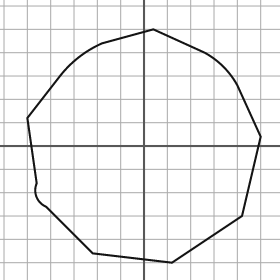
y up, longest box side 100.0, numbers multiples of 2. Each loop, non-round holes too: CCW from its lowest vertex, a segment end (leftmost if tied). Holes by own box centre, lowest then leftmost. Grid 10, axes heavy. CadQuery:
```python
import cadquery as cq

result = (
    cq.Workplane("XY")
    .moveTo(12.0, -50.0)
    .lineTo(42.0, -30.0)
    .lineTo(50.0, 4.0)
    .lineTo(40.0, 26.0)
    .threePointArc((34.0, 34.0), (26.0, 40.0))
    .lineTo(4.0, 50.0)
    .lineTo(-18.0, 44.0)
    .threePointArc((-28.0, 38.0), (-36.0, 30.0))
    .lineTo(-50.0, 12.0)
    .lineTo(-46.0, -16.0)
    .threePointArc((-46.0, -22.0), (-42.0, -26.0))
    .lineTo(-22.0, -46.0)
    .close()
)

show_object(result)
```